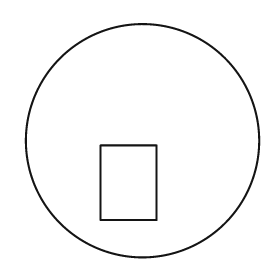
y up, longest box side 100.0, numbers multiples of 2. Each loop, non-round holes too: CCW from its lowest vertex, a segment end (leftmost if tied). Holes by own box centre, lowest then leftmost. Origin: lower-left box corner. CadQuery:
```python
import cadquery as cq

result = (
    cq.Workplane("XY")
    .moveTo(50.0, 50.0)
    .circle(50.0)
    .moveTo(32.0, 16.0)
    .lineTo(56.0, 16.0)
    .lineTo(56.0, 48.0)
    .lineTo(32.0, 48.0)
    .close()
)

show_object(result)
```